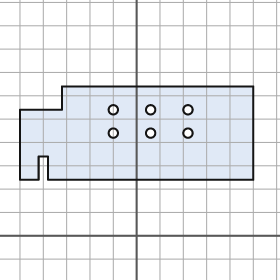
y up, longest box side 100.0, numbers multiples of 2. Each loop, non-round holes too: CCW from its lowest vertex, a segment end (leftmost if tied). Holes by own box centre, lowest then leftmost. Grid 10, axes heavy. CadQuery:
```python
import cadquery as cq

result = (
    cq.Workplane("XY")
    .moveTo(-50.0, 24.0)
    .lineTo(-42.0, 24.0)
    .lineTo(-42.0, 34.0)
    .lineTo(-38.0, 34.0)
    .lineTo(-38.0, 24.0)
    .lineTo(50.0, 24.0)
    .lineTo(50.0, 64.0)
    .lineTo(-32.0, 64.0)
    .lineTo(-32.0, 54.0)
    .lineTo(-50.0, 54.0)
    .close()
    .moveTo(-10.0, 44.0)
    .circle(2.0)
    .moveTo(6.0, 44.0)
    .circle(2.0)
    .moveTo(22.0, 44.0)
    .circle(2.0)
    .moveTo(-10.0, 54.0)
    .circle(2.0)
    .moveTo(6.0, 54.0)
    .circle(2.0)
    .moveTo(22.0, 54.0)
    .circle(2.0)
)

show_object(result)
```